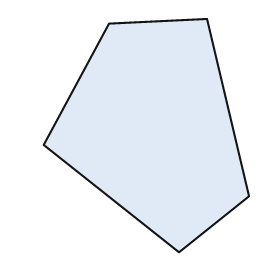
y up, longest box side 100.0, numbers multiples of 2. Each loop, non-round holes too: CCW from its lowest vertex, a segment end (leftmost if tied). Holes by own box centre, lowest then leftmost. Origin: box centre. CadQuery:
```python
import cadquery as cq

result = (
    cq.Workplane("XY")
    .moveTo(14.0, -50.0)
    .lineTo(44.0, -26.0)
    .lineTo(26.0, 50.0)
    .lineTo(-16.0, 48.0)
    .lineTo(-44.0, -4.0)
    .close()
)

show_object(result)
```